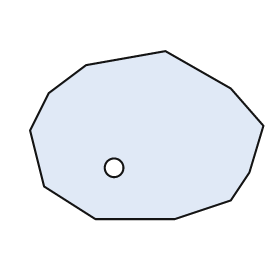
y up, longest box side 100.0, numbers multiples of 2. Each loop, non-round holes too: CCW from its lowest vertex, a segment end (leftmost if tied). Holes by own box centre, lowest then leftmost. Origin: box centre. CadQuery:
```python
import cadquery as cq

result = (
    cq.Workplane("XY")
    .moveTo(-22.0, -36.0)
    .lineTo(12.0, -36.0)
    .lineTo(36.0, -28.0)
    .lineTo(44.0, -16.0)
    .lineTo(50.0, 4.0)
    .lineTo(36.0, 20.0)
    .lineTo(8.0, 36.0)
    .lineTo(-26.0, 30.0)
    .lineTo(-42.0, 18.0)
    .lineTo(-50.0, 2.0)
    .lineTo(-44.0, -22.0)
    .close()
    .moveTo(-14.0, -14.0)
    .circle(4.0)
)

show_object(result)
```